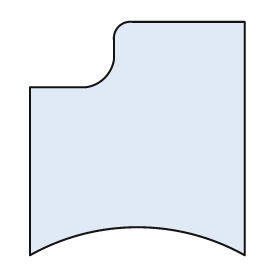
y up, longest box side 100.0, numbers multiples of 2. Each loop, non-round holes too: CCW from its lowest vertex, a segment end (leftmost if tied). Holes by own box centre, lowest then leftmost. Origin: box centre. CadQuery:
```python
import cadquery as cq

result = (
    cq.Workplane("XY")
    .moveTo(-46.0, -50.0)
    .threePointArc((0.0, -38.0), (46.0, -50.0))
    .lineTo(46.0, 50.0)
    .lineTo(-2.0, 50.0)
    .threePointArc((-8.0, 48.0), (-10.0, 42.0))
    .lineTo(-10.0, 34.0)
    .threePointArc((-14.0, 26.0), (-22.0, 22.0))
    .lineTo(-46.0, 22.0)
    .close()
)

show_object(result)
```